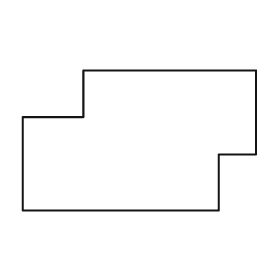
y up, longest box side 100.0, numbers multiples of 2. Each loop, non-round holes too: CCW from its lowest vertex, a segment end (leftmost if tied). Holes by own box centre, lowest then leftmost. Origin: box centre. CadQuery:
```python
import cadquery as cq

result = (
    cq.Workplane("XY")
    .moveTo(-50.0, -30.0)
    .lineTo(34.0, -30.0)
    .lineTo(34.0, -6.0)
    .lineTo(50.0, -6.0)
    .lineTo(50.0, 30.0)
    .lineTo(-24.0, 30.0)
    .lineTo(-24.0, 10.0)
    .lineTo(-50.0, 10.0)
    .close()
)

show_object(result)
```